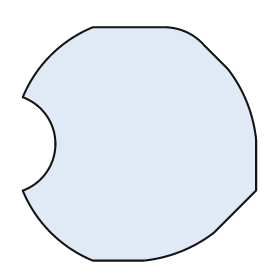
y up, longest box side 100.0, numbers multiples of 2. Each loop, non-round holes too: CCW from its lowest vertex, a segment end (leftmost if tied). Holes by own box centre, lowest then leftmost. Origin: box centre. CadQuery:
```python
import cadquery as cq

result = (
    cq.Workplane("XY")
    .moveTo(-20.0, -50.0)
    .lineTo(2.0, -50.0)
    .threePointArc((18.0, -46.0), (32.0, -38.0))
    .lineTo(50.0, -20.0)
    .lineTo(50.0, 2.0)
    .threePointArc((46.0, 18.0), (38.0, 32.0))
    .lineTo(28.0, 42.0)
    .threePointArc((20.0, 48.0), (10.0, 50.0))
    .lineTo(-20.0, 50.0)
    .threePointArc((-38.0, 38.0), (-50.0, 20.0))
    .threePointArc((-36.0, 0.0), (-50.0, -20.0))
    .threePointArc((-38.0, -38.0), (-20.0, -50.0))
    .close()
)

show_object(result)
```